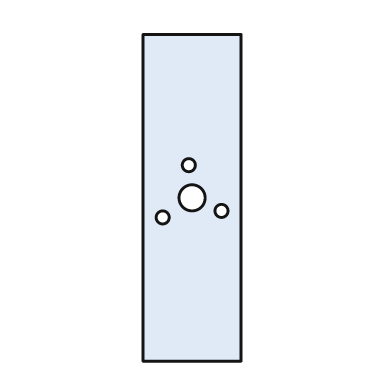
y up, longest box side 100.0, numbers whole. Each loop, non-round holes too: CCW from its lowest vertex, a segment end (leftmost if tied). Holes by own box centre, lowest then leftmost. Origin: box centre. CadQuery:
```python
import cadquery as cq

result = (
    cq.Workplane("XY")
    .moveTo(-15.0, -50.0)
    .lineTo(15.0, -50.0)
    .lineTo(15.0, 50.0)
    .lineTo(-15.0, 50.0)
    .close()
    .moveTo(-9.0, -6.0)
    .circle(2.0)
    .moveTo(9.0, -4.0)
    .circle(2.0)
    .moveTo(0.0, 0.0)
    .circle(4.0)
    .moveTo(-1.0, 10.0)
    .circle(2.0)
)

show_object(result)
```